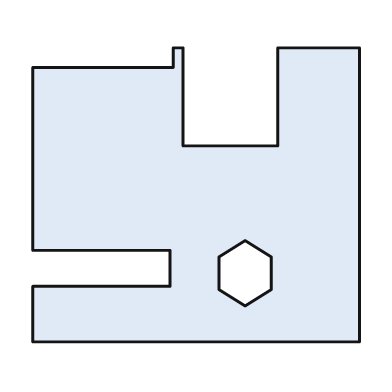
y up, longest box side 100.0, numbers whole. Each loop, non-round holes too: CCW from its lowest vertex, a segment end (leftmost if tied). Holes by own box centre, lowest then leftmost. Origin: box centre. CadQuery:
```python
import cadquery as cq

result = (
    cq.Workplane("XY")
    .moveTo(-50.0, -45.0)
    .lineTo(50.0, -45.0)
    .lineTo(50.0, 45.0)
    .lineTo(25.0, 45.0)
    .lineTo(25.0, 15.0)
    .lineTo(-4.0, 15.0)
    .lineTo(-4.0, 45.0)
    .lineTo(-7.0, 45.0)
    .lineTo(-7.0, 39.0)
    .lineTo(-50.0, 39.0)
    .lineTo(-50.0, -17.0)
    .lineTo(-8.0, -17.0)
    .lineTo(-8.0, -28.0)
    .lineTo(-50.0, -28.0)
    .close()
    .moveTo(15.0, -34.0)
    .lineTo(23.0, -29.0)
    .lineTo(23.0, -19.0)
    .lineTo(15.0, -14.0)
    .lineTo(7.0, -19.0)
    .lineTo(7.0, -29.0)
    .close()
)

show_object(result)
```